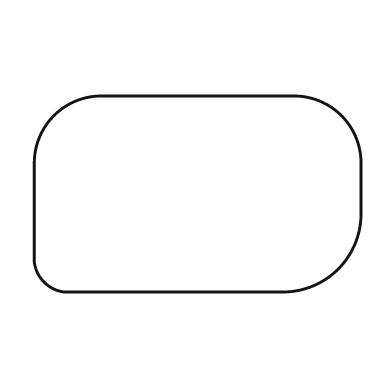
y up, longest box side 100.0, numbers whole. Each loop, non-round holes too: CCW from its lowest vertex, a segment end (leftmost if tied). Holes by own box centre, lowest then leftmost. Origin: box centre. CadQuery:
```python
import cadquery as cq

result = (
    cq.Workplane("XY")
    .moveTo(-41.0, -30.0)
    .lineTo(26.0, -30.0)
    .threePointArc((43.0, -23.0), (50.0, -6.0))
    .lineTo(50.0, 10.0)
    .threePointArc((44.0, 24.0), (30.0, 30.0))
    .lineTo(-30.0, 30.0)
    .threePointArc((-44.0, 24.0), (-50.0, 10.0))
    .lineTo(-50.0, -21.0)
    .threePointArc((-47.0, -27.0), (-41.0, -30.0))
    .close()
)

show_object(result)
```